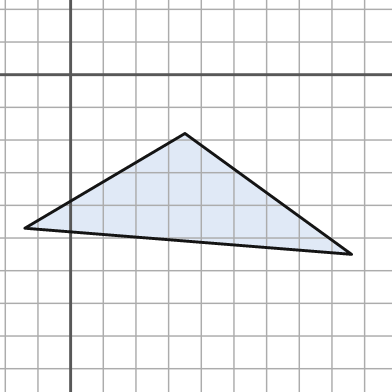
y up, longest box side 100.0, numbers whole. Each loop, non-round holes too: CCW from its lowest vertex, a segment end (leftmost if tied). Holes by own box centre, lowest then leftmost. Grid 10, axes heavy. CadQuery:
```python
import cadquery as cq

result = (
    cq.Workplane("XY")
    .moveTo(86.0, -55.0)
    .lineTo(35.0, -18.0)
    .lineTo(-14.0, -47.0)
    .close()
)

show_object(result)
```